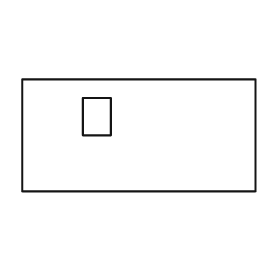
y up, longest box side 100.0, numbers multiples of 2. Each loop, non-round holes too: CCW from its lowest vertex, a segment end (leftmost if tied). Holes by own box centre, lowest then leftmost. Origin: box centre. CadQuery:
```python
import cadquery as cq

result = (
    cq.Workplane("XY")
    .moveTo(-50.0, -24.0)
    .lineTo(50.0, -24.0)
    .lineTo(50.0, 24.0)
    .lineTo(-50.0, 24.0)
    .close()
    .moveTo(-24.0, 0.0)
    .lineTo(-12.0, 0.0)
    .lineTo(-12.0, 16.0)
    .lineTo(-24.0, 16.0)
    .close()
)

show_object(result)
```